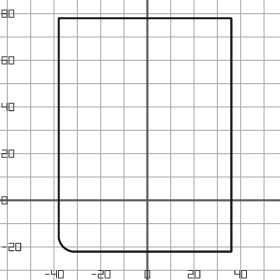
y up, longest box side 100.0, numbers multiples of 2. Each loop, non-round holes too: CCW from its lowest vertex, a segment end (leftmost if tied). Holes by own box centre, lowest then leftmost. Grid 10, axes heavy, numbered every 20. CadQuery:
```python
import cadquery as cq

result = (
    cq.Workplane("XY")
    .moveTo(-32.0, -22.0)
    .lineTo(36.0, -22.0)
    .lineTo(36.0, 78.0)
    .lineTo(-38.0, 78.0)
    .lineTo(-38.0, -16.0)
    .threePointArc((-36.0, -20.0), (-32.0, -22.0))
    .close()
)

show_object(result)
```